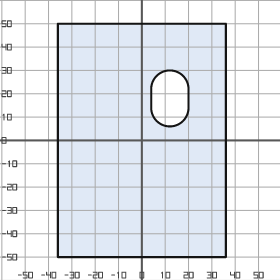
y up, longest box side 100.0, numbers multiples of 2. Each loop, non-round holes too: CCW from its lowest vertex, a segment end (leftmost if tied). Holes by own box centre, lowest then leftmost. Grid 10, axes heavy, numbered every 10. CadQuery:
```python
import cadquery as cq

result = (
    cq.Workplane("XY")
    .moveTo(-36.0, -50.0)
    .lineTo(36.0, -50.0)
    .lineTo(36.0, 50.0)
    .lineTo(-36.0, 50.0)
    .close()
    .moveTo(4.0, 14.0)
    .threePointArc((12.0, 6.0), (20.0, 14.0))
    .lineTo(20.0, 22.0)
    .threePointArc((12.0, 30.0), (4.0, 22.0))
    .close()
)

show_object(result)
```